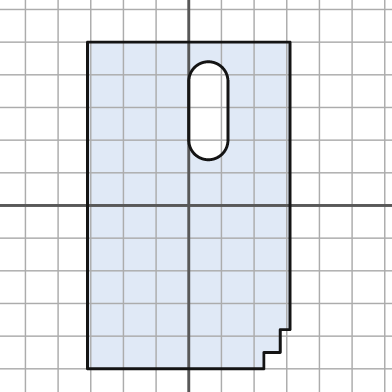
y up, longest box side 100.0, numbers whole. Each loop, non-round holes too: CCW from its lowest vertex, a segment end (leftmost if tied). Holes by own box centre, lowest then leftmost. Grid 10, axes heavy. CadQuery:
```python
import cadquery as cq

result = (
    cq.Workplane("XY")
    .moveTo(-31.0, -50.0)
    .lineTo(23.0, -50.0)
    .lineTo(23.0, -45.0)
    .lineTo(28.0, -45.0)
    .lineTo(28.0, -38.0)
    .lineTo(31.0, -38.0)
    .lineTo(31.0, 50.0)
    .lineTo(-31.0, 50.0)
    .close()
    .moveTo(0.0, 20.0)
    .threePointArc((6.0, 14.0), (12.0, 20.0))
    .lineTo(12.0, 38.0)
    .threePointArc((6.0, 44.0), (0.0, 38.0))
    .close()
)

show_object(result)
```